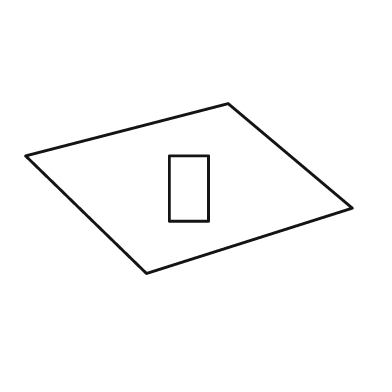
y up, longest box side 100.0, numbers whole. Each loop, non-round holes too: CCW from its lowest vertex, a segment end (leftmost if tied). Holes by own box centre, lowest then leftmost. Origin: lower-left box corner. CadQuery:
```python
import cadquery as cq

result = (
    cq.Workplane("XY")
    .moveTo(37.0, 0.0)
    .lineTo(100.0, 20.0)
    .lineTo(62.0, 52.0)
    .lineTo(0.0, 36.0)
    .close()
    .moveTo(44.0, 16.0)
    .lineTo(56.0, 16.0)
    .lineTo(56.0, 36.0)
    .lineTo(44.0, 36.0)
    .close()
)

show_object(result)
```